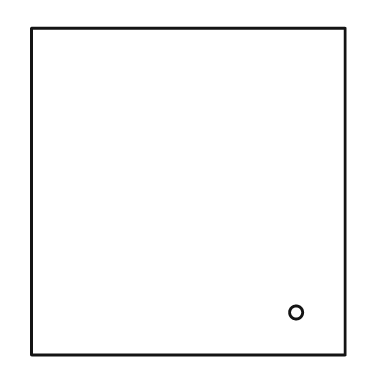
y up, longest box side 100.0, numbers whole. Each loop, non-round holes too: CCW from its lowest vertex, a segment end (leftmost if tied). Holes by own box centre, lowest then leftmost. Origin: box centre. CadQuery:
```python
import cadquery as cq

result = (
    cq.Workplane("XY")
    .moveTo(-48.0, -50.0)
    .lineTo(48.0, -50.0)
    .lineTo(48.0, 50.0)
    .lineTo(-48.0, 50.0)
    .close()
    .moveTo(33.0, -37.0)
    .circle(2.0)
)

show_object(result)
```